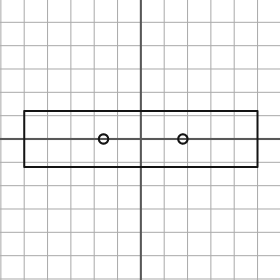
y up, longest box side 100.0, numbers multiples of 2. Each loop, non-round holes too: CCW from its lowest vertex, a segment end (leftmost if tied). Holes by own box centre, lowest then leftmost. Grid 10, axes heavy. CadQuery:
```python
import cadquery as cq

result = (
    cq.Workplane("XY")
    .moveTo(-50.0, -12.0)
    .lineTo(50.0, -12.0)
    .lineTo(50.0, 12.0)
    .lineTo(-50.0, 12.0)
    .close()
    .moveTo(-16.0, 0.0)
    .circle(2.0)
    .moveTo(18.0, 0.0)
    .circle(2.0)
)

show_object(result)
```